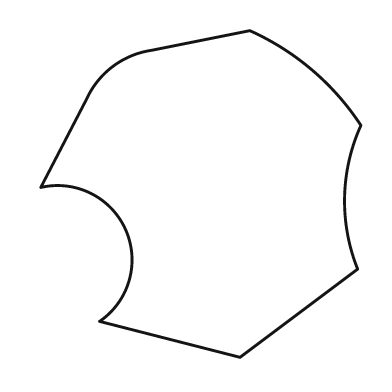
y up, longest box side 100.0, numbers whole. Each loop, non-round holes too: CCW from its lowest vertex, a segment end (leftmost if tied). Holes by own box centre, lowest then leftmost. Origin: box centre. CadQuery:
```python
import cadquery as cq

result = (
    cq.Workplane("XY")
    .moveTo(12.0, -50.0)
    .lineTo(48.0, -23.0)
    .threePointArc((44.0, -1.0), (49.0, 21.0))
    .threePointArc((34.0, 38.0), (15.0, 50.0))
    .lineTo(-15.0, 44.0)
    .threePointArc((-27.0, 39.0), (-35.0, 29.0))
    .lineTo(-49.0, 2.0)
    .threePointArc((-23.0, -11.0), (-31.0, -39.0))
    .close()
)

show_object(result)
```